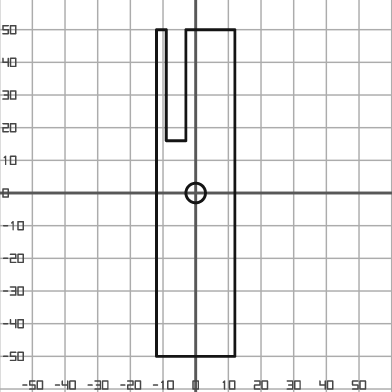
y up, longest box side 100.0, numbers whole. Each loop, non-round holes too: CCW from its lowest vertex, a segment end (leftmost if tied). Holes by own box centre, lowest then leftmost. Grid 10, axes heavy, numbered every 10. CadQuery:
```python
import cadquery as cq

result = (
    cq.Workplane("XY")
    .moveTo(-12.0, -50.0)
    .lineTo(12.0, -50.0)
    .lineTo(12.0, 50.0)
    .lineTo(-3.0, 50.0)
    .lineTo(-3.0, 16.0)
    .lineTo(-9.0, 16.0)
    .lineTo(-9.0, 50.0)
    .lineTo(-12.0, 50.0)
    .close()
    .moveTo(0.0, 0.0)
    .circle(3.0)
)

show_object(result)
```